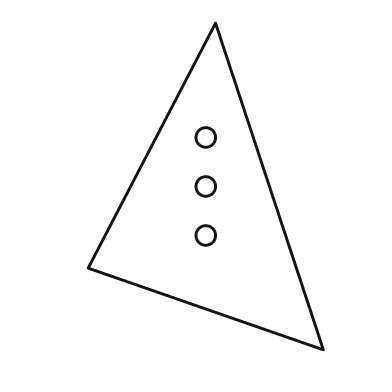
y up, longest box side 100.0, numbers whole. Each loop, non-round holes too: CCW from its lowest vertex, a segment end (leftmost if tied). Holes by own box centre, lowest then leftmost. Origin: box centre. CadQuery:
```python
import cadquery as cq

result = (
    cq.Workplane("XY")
    .moveTo(36.0, -50.0)
    .lineTo(3.0, 50.0)
    .lineTo(-36.0, -25.0)
    .close()
    .moveTo(0.0, -15.0)
    .circle(3.0)
    .moveTo(0.0, 0.0)
    .circle(3.0)
    .moveTo(0.0, 15.0)
    .circle(3.0)
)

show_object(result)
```